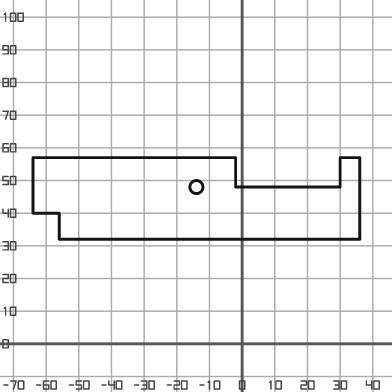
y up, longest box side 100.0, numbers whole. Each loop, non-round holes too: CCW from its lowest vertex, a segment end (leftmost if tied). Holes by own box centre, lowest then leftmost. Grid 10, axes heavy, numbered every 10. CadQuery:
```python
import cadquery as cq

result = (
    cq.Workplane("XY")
    .moveTo(-56.0, 32.0)
    .lineTo(36.0, 32.0)
    .lineTo(36.0, 57.0)
    .lineTo(30.0, 57.0)
    .lineTo(30.0, 48.0)
    .lineTo(-2.0, 48.0)
    .lineTo(-2.0, 57.0)
    .lineTo(-64.0, 57.0)
    .lineTo(-64.0, 40.0)
    .lineTo(-56.0, 40.0)
    .close()
    .moveTo(-14.0, 48.0)
    .circle(2.0)
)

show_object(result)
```